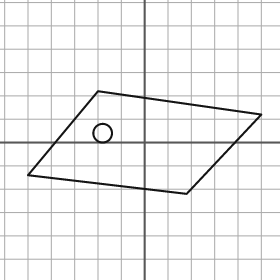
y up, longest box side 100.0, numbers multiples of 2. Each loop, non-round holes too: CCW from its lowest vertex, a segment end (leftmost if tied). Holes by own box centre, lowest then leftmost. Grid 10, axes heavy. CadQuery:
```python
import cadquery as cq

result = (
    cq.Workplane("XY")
    .moveTo(18.0, -22.0)
    .lineTo(50.0, 12.0)
    .lineTo(-20.0, 22.0)
    .lineTo(-50.0, -14.0)
    .close()
    .moveTo(-18.0, 4.0)
    .circle(4.0)
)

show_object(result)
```